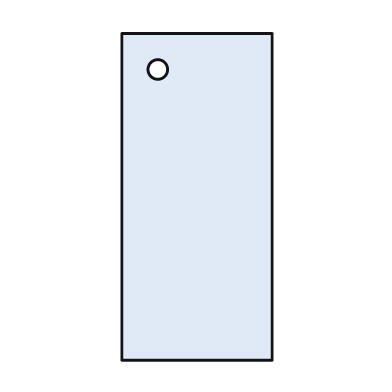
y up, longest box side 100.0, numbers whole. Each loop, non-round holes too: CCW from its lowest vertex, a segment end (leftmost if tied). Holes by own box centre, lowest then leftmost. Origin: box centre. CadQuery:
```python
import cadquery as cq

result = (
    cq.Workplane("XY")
    .moveTo(-23.0, -50.0)
    .lineTo(23.0, -50.0)
    .lineTo(23.0, 50.0)
    .lineTo(-23.0, 50.0)
    .close()
    .moveTo(-12.0, 39.0)
    .circle(3.0)
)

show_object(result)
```